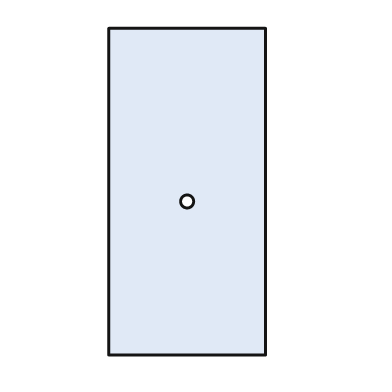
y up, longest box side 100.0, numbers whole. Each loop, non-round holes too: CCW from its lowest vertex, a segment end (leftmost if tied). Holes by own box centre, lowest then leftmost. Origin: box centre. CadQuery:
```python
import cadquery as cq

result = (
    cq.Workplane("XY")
    .moveTo(-24.0, -50.0)
    .lineTo(24.0, -50.0)
    .lineTo(24.0, 50.0)
    .lineTo(-24.0, 50.0)
    .close()
    .moveTo(0.0, -3.0)
    .circle(2.0)
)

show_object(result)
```